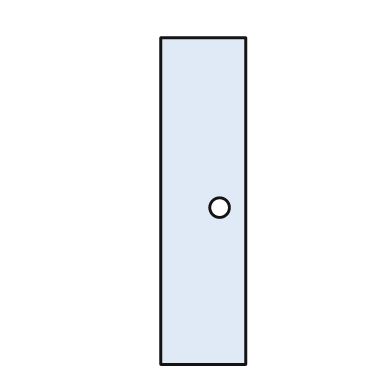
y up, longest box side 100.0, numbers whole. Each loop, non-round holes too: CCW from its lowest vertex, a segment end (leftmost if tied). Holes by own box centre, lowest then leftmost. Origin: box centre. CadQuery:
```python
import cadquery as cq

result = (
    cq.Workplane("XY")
    .moveTo(-13.0, -50.0)
    .lineTo(13.0, -50.0)
    .lineTo(13.0, 50.0)
    .lineTo(-13.0, 50.0)
    .close()
    .moveTo(5.0, -2.0)
    .circle(3.0)
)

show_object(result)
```